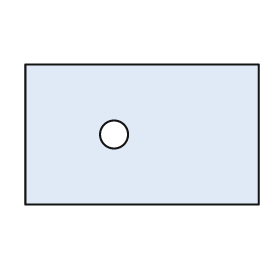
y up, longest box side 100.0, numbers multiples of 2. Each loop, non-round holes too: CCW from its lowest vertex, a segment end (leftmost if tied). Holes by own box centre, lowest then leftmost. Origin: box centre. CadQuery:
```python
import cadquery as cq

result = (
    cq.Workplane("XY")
    .moveTo(-50.0, -30.0)
    .lineTo(50.0, -30.0)
    .lineTo(50.0, 30.0)
    .lineTo(-50.0, 30.0)
    .close()
    .moveTo(-12.0, 0.0)
    .circle(6.0)
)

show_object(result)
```